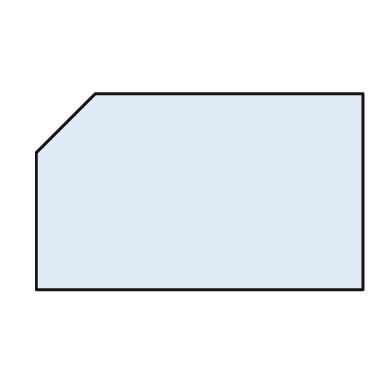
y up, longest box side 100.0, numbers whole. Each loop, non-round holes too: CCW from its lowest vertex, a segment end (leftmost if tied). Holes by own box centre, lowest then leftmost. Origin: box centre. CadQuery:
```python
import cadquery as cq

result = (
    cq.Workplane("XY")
    .moveTo(-50.0, -30.0)
    .lineTo(50.0, -30.0)
    .lineTo(50.0, 30.0)
    .lineTo(-32.0, 30.0)
    .lineTo(-50.0, 12.0)
    .close()
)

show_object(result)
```